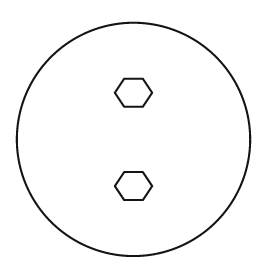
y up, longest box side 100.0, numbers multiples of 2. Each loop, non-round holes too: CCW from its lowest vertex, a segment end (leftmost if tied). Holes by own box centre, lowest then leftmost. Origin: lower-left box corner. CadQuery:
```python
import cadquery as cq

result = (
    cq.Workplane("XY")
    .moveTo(50.0, 50.0)
    .circle(50.0)
    .moveTo(46.0, 24.0)
    .lineTo(54.0, 24.0)
    .lineTo(58.0, 30.0)
    .lineTo(54.0, 36.0)
    .lineTo(46.0, 36.0)
    .lineTo(42.0, 30.0)
    .close()
    .moveTo(46.0, 64.0)
    .lineTo(54.0, 64.0)
    .lineTo(58.0, 70.0)
    .lineTo(54.0, 76.0)
    .lineTo(46.0, 76.0)
    .lineTo(42.0, 70.0)
    .close()
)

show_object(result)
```